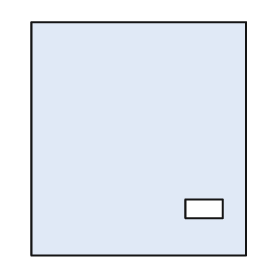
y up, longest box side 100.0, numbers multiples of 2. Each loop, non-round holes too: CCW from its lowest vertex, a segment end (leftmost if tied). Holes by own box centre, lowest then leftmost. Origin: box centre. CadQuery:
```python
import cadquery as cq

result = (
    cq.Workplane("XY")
    .moveTo(-46.0, -50.0)
    .lineTo(46.0, -50.0)
    .lineTo(46.0, 50.0)
    .lineTo(-46.0, 50.0)
    .close()
    .moveTo(20.0, -34.0)
    .lineTo(36.0, -34.0)
    .lineTo(36.0, -26.0)
    .lineTo(20.0, -26.0)
    .close()
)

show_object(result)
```